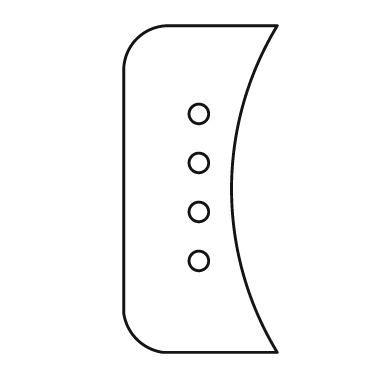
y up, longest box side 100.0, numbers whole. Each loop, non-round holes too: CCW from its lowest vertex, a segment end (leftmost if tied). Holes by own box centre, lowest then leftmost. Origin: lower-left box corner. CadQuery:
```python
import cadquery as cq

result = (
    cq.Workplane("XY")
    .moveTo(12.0, 0.0)
    .lineTo(47.0, 0.0)
    .threePointArc((33.0, 50.0), (47.0, 100.0))
    .lineTo(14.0, 100.0)
    .threePointArc((4.0, 96.0), (0.0, 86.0))
    .lineTo(0.0, 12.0)
    .threePointArc((4.0, 4.0), (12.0, 0.0))
    .close()
    .moveTo(23.0, 28.0)
    .circle(3.0)
    .moveTo(23.0, 43.0)
    .circle(3.0)
    .moveTo(23.0, 58.0)
    .circle(3.0)
    .moveTo(23.0, 73.0)
    .circle(3.0)
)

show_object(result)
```